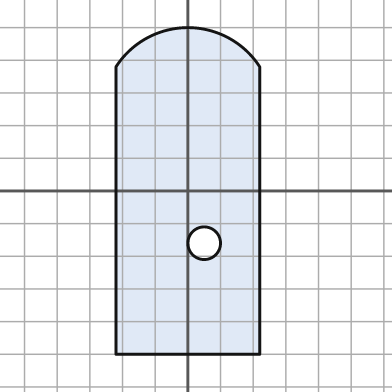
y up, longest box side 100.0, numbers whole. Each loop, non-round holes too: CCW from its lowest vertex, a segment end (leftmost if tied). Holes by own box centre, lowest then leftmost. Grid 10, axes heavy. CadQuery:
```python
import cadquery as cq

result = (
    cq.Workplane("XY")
    .moveTo(-22.0, -50.0)
    .lineTo(22.0, -50.0)
    .lineTo(22.0, 38.0)
    .threePointArc((0.0, 50.0), (-22.0, 38.0))
    .close()
    .moveTo(5.0, -16.0)
    .circle(5.0)
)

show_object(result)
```